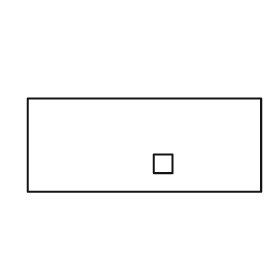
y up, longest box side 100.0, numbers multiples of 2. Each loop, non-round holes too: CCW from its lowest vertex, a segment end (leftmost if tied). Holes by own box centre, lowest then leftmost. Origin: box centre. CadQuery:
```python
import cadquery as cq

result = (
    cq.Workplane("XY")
    .moveTo(-50.0, -20.0)
    .lineTo(50.0, -20.0)
    .lineTo(50.0, 20.0)
    .lineTo(-50.0, 20.0)
    .close()
    .moveTo(4.0, -12.0)
    .lineTo(12.0, -12.0)
    .lineTo(12.0, -4.0)
    .lineTo(4.0, -4.0)
    .close()
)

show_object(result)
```